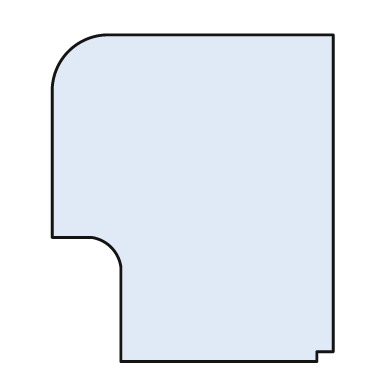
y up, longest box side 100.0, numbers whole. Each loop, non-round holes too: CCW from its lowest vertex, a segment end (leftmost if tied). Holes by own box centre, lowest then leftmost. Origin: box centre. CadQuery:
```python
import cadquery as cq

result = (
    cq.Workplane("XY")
    .moveTo(-22.0, -50.0)
    .lineTo(38.0, -50.0)
    .lineTo(38.0, -47.0)
    .lineTo(43.0, -47.0)
    .lineTo(43.0, 50.0)
    .lineTo(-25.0, 50.0)
    .threePointArc((-38.0, 45.0), (-43.0, 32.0))
    .lineTo(-43.0, -12.0)
    .lineTo(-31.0, -12.0)
    .threePointArc((-25.0, -15.0), (-22.0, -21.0))
    .close()
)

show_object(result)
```